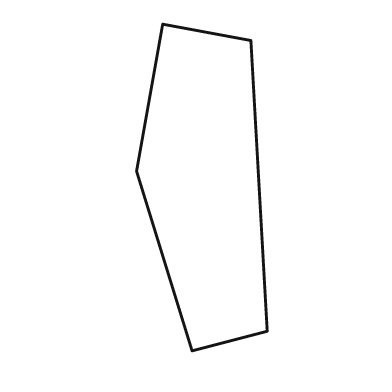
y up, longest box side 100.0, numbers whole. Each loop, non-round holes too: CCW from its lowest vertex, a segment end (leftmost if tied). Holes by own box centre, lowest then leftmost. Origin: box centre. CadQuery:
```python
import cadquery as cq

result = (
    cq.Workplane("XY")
    .moveTo(-3.0, -50.0)
    .lineTo(20.0, -44.0)
    .lineTo(15.0, 45.0)
    .lineTo(-12.0, 50.0)
    .lineTo(-20.0, 5.0)
    .close()
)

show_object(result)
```